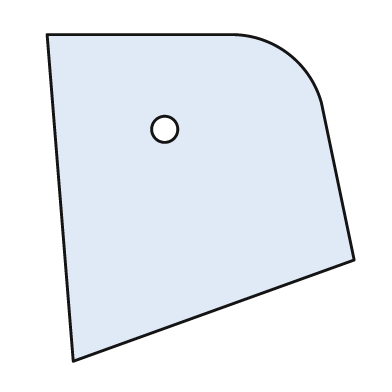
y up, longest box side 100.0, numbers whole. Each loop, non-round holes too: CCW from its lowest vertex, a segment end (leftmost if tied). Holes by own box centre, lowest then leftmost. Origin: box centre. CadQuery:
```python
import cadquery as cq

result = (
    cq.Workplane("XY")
    .moveTo(-39.0, -50.0)
    .lineTo(47.0, -19.0)
    .lineTo(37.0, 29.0)
    .threePointArc((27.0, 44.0), (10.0, 50.0))
    .lineTo(-47.0, 50.0)
    .close()
    .moveTo(-11.0, 21.0)
    .circle(4.0)
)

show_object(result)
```